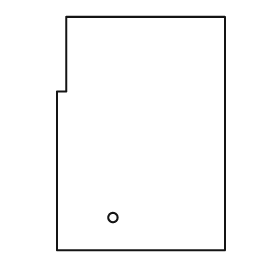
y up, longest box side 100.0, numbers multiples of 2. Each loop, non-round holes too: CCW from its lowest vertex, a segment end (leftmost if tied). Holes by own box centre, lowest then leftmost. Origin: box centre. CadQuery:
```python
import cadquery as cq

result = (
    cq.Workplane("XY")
    .moveTo(-36.0, -50.0)
    .lineTo(36.0, -50.0)
    .lineTo(36.0, 50.0)
    .lineTo(-32.0, 50.0)
    .lineTo(-32.0, 18.0)
    .lineTo(-36.0, 18.0)
    .close()
    .moveTo(-12.0, -36.0)
    .circle(2.0)
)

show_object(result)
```